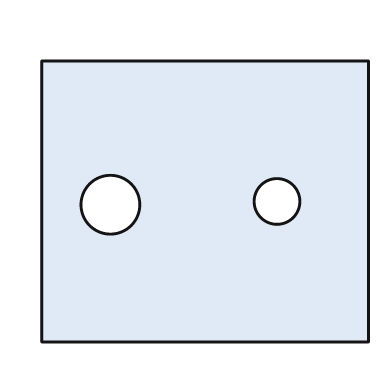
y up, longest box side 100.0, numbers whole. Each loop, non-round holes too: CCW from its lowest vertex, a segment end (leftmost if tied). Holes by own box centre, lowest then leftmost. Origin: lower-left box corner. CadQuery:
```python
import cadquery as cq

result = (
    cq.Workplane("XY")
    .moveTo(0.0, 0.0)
    .lineTo(100.0, 0.0)
    .lineTo(100.0, 86.0)
    .lineTo(0.0, 86.0)
    .close()
    .moveTo(21.0, 42.0)
    .circle(9.0)
    .moveTo(72.0, 43.0)
    .circle(7.0)
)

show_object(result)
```